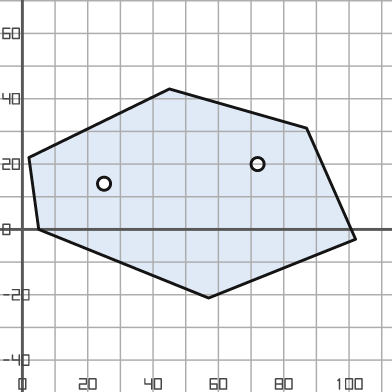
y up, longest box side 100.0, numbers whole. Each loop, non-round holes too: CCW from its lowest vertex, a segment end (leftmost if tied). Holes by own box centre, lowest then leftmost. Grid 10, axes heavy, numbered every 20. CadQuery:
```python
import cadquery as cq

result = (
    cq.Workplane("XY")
    .moveTo(57.0, -21.0)
    .lineTo(102.0, -3.0)
    .lineTo(87.0, 31.0)
    .lineTo(45.0, 43.0)
    .lineTo(2.0, 22.0)
    .lineTo(5.0, 0.0)
    .close()
    .moveTo(25.0, 14.0)
    .circle(2.0)
    .moveTo(72.0, 20.0)
    .circle(2.0)
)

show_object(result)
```